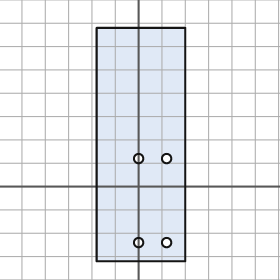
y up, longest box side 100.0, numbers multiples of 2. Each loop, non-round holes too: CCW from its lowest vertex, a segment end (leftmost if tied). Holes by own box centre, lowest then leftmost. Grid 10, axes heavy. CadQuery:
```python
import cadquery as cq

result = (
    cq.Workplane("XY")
    .moveTo(-18.0, -32.0)
    .lineTo(20.0, -32.0)
    .lineTo(20.0, 68.0)
    .lineTo(-18.0, 68.0)
    .close()
    .moveTo(0.0, -24.0)
    .circle(2.0)
    .moveTo(12.0, -24.0)
    .circle(2.0)
    .moveTo(0.0, 12.0)
    .circle(2.0)
    .moveTo(12.0, 12.0)
    .circle(2.0)
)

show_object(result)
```